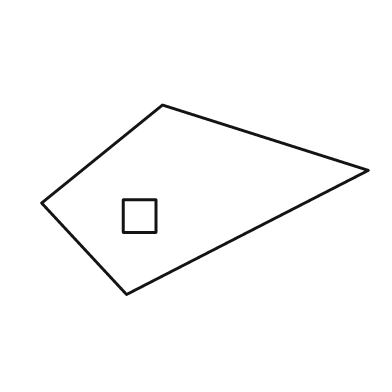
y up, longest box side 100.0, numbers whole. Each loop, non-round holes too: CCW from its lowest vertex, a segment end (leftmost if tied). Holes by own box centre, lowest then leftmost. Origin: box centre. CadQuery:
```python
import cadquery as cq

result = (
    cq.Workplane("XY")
    .moveTo(-24.0, -29.0)
    .lineTo(50.0, 9.0)
    .lineTo(-13.0, 29.0)
    .lineTo(-50.0, -1.0)
    .close()
    .moveTo(-25.0, -10.0)
    .lineTo(-15.0, -10.0)
    .lineTo(-15.0, 0.0)
    .lineTo(-25.0, 0.0)
    .close()
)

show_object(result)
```